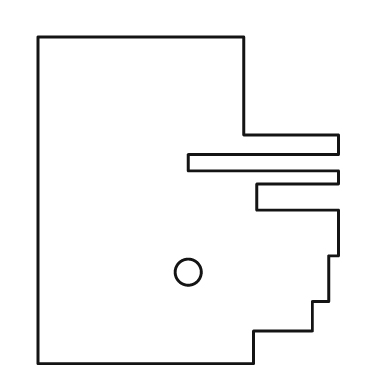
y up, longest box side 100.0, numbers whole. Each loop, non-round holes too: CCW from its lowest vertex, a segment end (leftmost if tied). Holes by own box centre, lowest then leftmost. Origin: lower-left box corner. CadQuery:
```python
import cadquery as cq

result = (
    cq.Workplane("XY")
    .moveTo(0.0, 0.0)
    .lineTo(66.0, 0.0)
    .lineTo(66.0, 10.0)
    .lineTo(84.0, 10.0)
    .lineTo(84.0, 19.0)
    .lineTo(89.0, 19.0)
    .lineTo(89.0, 33.0)
    .lineTo(92.0, 33.0)
    .lineTo(92.0, 47.0)
    .lineTo(67.0, 47.0)
    .lineTo(67.0, 55.0)
    .lineTo(92.0, 55.0)
    .lineTo(92.0, 59.0)
    .lineTo(46.0, 59.0)
    .lineTo(46.0, 64.0)
    .lineTo(92.0, 64.0)
    .lineTo(92.0, 70.0)
    .lineTo(63.0, 70.0)
    .lineTo(63.0, 100.0)
    .lineTo(0.0, 100.0)
    .close()
    .moveTo(46.0, 28.0)
    .circle(4.0)
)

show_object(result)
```